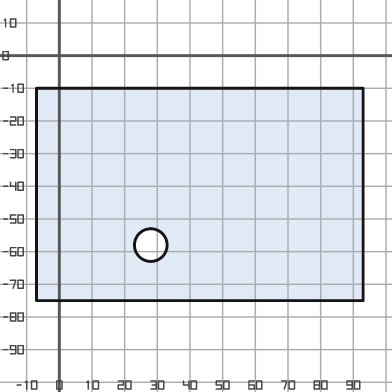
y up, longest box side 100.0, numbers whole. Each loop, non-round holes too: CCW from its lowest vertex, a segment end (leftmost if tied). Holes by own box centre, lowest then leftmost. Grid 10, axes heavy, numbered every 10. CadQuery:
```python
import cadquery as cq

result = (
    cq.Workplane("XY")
    .moveTo(-7.0, -75.0)
    .lineTo(93.0, -75.0)
    .lineTo(93.0, -10.0)
    .lineTo(-7.0, -10.0)
    .close()
    .moveTo(28.0, -58.0)
    .circle(5.0)
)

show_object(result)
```